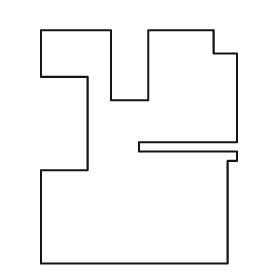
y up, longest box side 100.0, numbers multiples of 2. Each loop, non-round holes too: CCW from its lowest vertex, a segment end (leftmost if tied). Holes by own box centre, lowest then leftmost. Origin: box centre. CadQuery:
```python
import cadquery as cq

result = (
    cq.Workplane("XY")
    .moveTo(-42.0, -50.0)
    .lineTo(38.0, -50.0)
    .lineTo(38.0, -6.0)
    .lineTo(42.0, -6.0)
    .lineTo(42.0, -2.0)
    .lineTo(0.0, -2.0)
    .lineTo(0.0, 2.0)
    .lineTo(42.0, 2.0)
    .lineTo(42.0, 40.0)
    .lineTo(32.0, 40.0)
    .lineTo(32.0, 50.0)
    .lineTo(4.0, 50.0)
    .lineTo(4.0, 20.0)
    .lineTo(-12.0, 20.0)
    .lineTo(-12.0, 50.0)
    .lineTo(-42.0, 50.0)
    .lineTo(-42.0, 30.0)
    .lineTo(-22.0, 30.0)
    .lineTo(-22.0, -10.0)
    .lineTo(-42.0, -10.0)
    .close()
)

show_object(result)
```